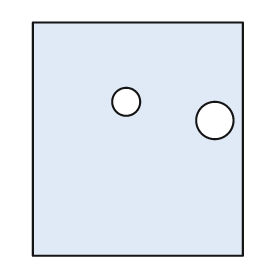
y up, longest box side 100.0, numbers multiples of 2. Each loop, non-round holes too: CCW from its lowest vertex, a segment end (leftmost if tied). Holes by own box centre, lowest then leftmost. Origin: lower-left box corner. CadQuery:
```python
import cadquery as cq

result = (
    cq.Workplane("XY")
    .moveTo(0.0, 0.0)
    .lineTo(90.0, 0.0)
    .lineTo(90.0, 100.0)
    .lineTo(0.0, 100.0)
    .close()
    .moveTo(78.0, 58.0)
    .circle(8.0)
    .moveTo(40.0, 66.0)
    .circle(6.0)
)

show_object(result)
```